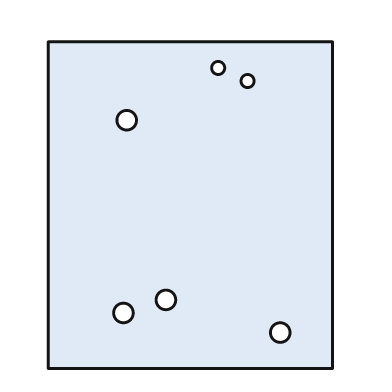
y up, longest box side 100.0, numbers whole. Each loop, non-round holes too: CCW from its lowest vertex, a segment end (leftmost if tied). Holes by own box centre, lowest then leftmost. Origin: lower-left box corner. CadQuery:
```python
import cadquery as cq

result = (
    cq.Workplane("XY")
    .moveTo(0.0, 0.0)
    .lineTo(87.0, 0.0)
    .lineTo(87.0, 100.0)
    .lineTo(0.0, 100.0)
    .close()
    .moveTo(71.0, 11.0)
    .circle(3.0)
    .moveTo(23.0, 17.0)
    .circle(3.0)
    .moveTo(36.0, 21.0)
    .circle(3.0)
    .moveTo(24.0, 76.0)
    .circle(3.0)
    .moveTo(61.0, 88.0)
    .circle(2.0)
    .moveTo(52.0, 92.0)
    .circle(2.0)
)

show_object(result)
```